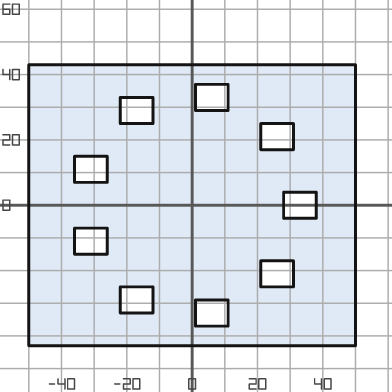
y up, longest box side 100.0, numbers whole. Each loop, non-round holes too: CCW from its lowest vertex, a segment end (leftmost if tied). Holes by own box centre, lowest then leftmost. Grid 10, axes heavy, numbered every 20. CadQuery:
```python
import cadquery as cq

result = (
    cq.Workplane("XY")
    .moveTo(-50.0, -43.0)
    .lineTo(50.0, -43.0)
    .lineTo(50.0, 43.0)
    .lineTo(-50.0, 43.0)
    .close()
    .moveTo(1.0, -37.0)
    .lineTo(11.0, -37.0)
    .lineTo(11.0, -29.0)
    .lineTo(1.0, -29.0)
    .close()
    .moveTo(-22.0, -33.0)
    .lineTo(-12.0, -33.0)
    .lineTo(-12.0, -25.0)
    .lineTo(-22.0, -25.0)
    .close()
    .moveTo(21.0, -25.0)
    .lineTo(31.0, -25.0)
    .lineTo(31.0, -17.0)
    .lineTo(21.0, -17.0)
    .close()
    .moveTo(-36.0, -15.0)
    .lineTo(-26.0, -15.0)
    .lineTo(-26.0, -7.0)
    .lineTo(-36.0, -7.0)
    .close()
    .moveTo(28.0, -4.0)
    .lineTo(38.0, -4.0)
    .lineTo(38.0, 4.0)
    .lineTo(28.0, 4.0)
    .close()
    .moveTo(-36.0, 7.0)
    .lineTo(-26.0, 7.0)
    .lineTo(-26.0, 15.0)
    .lineTo(-36.0, 15.0)
    .close()
    .moveTo(21.0, 17.0)
    .lineTo(31.0, 17.0)
    .lineTo(31.0, 25.0)
    .lineTo(21.0, 25.0)
    .close()
    .moveTo(-22.0, 25.0)
    .lineTo(-12.0, 25.0)
    .lineTo(-12.0, 33.0)
    .lineTo(-22.0, 33.0)
    .close()
    .moveTo(1.0, 29.0)
    .lineTo(11.0, 29.0)
    .lineTo(11.0, 37.0)
    .lineTo(1.0, 37.0)
    .close()
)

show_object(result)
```